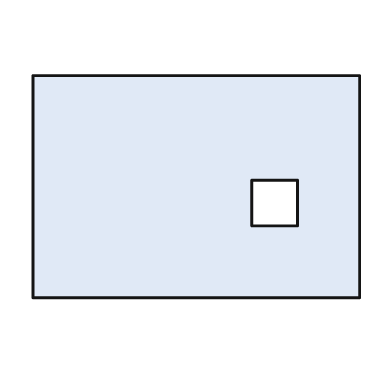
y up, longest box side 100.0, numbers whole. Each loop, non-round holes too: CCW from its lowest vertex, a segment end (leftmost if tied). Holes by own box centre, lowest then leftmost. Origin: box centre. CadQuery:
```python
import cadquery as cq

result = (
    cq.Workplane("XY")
    .moveTo(-50.0, -34.0)
    .lineTo(50.0, -34.0)
    .lineTo(50.0, 34.0)
    .lineTo(-50.0, 34.0)
    .close()
    .moveTo(17.0, -12.0)
    .lineTo(31.0, -12.0)
    .lineTo(31.0, 2.0)
    .lineTo(17.0, 2.0)
    .close()
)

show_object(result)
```